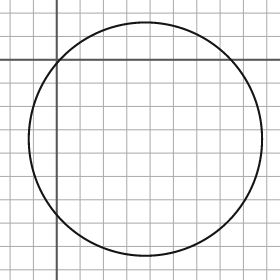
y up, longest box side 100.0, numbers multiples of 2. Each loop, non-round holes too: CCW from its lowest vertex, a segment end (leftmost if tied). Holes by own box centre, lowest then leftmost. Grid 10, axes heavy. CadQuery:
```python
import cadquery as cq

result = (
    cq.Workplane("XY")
    .moveTo(38.0, -34.0)
    .circle(50.0)
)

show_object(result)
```